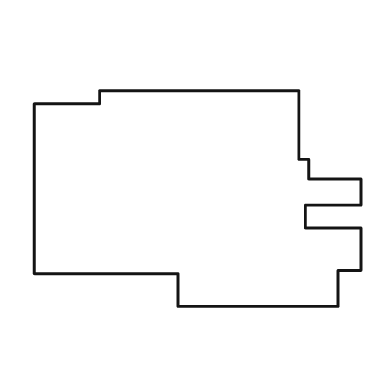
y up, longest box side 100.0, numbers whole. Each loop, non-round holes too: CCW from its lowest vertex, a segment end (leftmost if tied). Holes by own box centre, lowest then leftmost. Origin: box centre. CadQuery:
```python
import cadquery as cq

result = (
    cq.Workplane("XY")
    .moveTo(-6.0, -33.0)
    .lineTo(43.0, -33.0)
    .lineTo(43.0, -22.0)
    .lineTo(50.0, -22.0)
    .lineTo(50.0, -9.0)
    .lineTo(33.0, -9.0)
    .lineTo(33.0, -2.0)
    .lineTo(50.0, -2.0)
    .lineTo(50.0, 6.0)
    .lineTo(34.0, 6.0)
    .lineTo(34.0, 12.0)
    .lineTo(31.0, 12.0)
    .lineTo(31.0, 33.0)
    .lineTo(-30.0, 33.0)
    .lineTo(-30.0, 29.0)
    .lineTo(-50.0, 29.0)
    .lineTo(-50.0, -23.0)
    .lineTo(-6.0, -23.0)
    .close()
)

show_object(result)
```